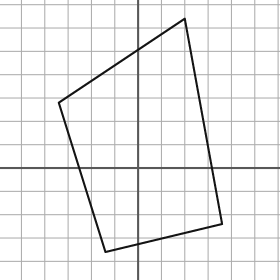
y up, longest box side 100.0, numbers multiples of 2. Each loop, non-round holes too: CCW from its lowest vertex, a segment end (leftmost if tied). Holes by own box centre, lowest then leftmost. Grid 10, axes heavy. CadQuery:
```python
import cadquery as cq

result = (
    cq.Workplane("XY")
    .moveTo(-14.0, -36.0)
    .lineTo(36.0, -24.0)
    .lineTo(20.0, 64.0)
    .lineTo(-34.0, 28.0)
    .close()
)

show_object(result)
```